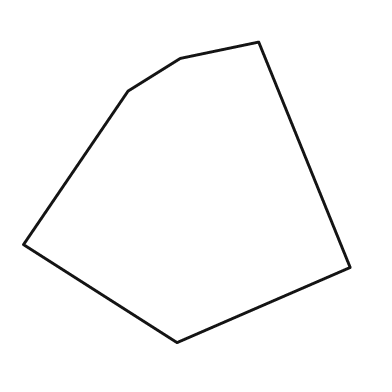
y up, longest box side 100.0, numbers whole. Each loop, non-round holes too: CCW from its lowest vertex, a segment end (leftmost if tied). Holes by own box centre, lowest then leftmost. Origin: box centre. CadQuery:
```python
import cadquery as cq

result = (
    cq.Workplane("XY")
    .moveTo(-3.0, -46.0)
    .lineTo(50.0, -23.0)
    .lineTo(22.0, 46.0)
    .lineTo(-2.0, 41.0)
    .lineTo(-18.0, 31.0)
    .lineTo(-50.0, -16.0)
    .close()
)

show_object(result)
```